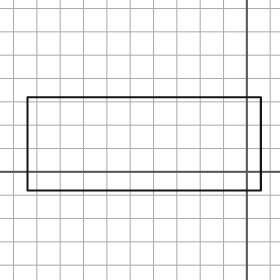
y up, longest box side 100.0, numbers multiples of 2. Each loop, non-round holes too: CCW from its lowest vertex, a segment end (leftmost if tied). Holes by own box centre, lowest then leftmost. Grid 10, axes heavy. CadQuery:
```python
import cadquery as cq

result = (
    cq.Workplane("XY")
    .moveTo(-94.0, -8.0)
    .lineTo(6.0, -8.0)
    .lineTo(6.0, 32.0)
    .lineTo(-94.0, 32.0)
    .close()
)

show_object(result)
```